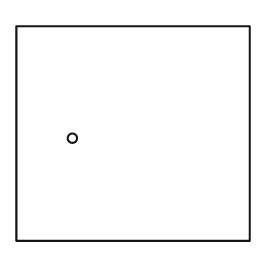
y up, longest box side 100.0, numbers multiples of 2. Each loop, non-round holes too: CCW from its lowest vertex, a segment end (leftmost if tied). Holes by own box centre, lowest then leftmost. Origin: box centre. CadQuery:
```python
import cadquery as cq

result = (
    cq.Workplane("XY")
    .moveTo(-50.0, -46.0)
    .lineTo(50.0, -46.0)
    .lineTo(50.0, 46.0)
    .lineTo(-50.0, 46.0)
    .close()
    .moveTo(-26.0, -2.0)
    .circle(2.0)
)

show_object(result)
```